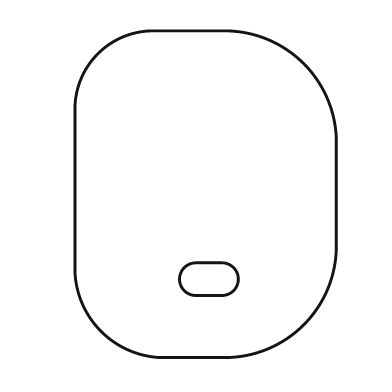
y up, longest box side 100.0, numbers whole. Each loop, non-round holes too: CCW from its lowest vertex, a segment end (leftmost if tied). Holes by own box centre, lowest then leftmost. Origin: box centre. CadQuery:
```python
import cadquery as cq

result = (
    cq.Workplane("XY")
    .moveTo(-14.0, -50.0)
    .lineTo(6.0, -50.0)
    .threePointArc((30.0, -40.0), (40.0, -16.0))
    .lineTo(40.0, 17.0)
    .threePointArc((30.0, 40.0), (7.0, 50.0))
    .lineTo(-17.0, 50.0)
    .threePointArc((-33.0, 43.0), (-40.0, 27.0))
    .lineTo(-40.0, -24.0)
    .threePointArc((-32.0, -42.0), (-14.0, -50.0))
    .close()
    .moveTo(-3.0, -31.0)
    .lineTo(5.0, -31.0)
    .threePointArc((10.0, -26.0), (5.0, -21.0))
    .lineTo(-3.0, -21.0)
    .threePointArc((-8.0, -26.0), (-3.0, -31.0))
    .close()
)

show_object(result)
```